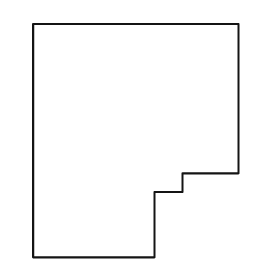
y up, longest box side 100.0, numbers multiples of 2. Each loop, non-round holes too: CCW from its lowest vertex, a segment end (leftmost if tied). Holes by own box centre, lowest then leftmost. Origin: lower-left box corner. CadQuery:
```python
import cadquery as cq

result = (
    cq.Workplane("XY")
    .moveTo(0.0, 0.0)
    .lineTo(52.0, 0.0)
    .lineTo(52.0, 28.0)
    .lineTo(64.0, 28.0)
    .lineTo(64.0, 36.0)
    .lineTo(88.0, 36.0)
    .lineTo(88.0, 100.0)
    .lineTo(0.0, 100.0)
    .close()
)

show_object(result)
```